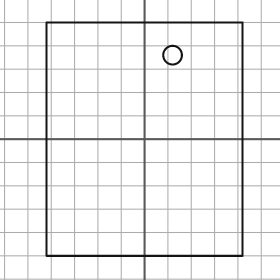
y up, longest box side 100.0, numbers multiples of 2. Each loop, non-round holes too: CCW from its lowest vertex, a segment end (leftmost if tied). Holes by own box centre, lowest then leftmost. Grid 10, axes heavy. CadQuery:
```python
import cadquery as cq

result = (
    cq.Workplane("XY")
    .moveTo(-42.0, -50.0)
    .lineTo(42.0, -50.0)
    .lineTo(42.0, 50.0)
    .lineTo(-42.0, 50.0)
    .close()
    .moveTo(12.0, 36.0)
    .circle(4.0)
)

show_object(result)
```